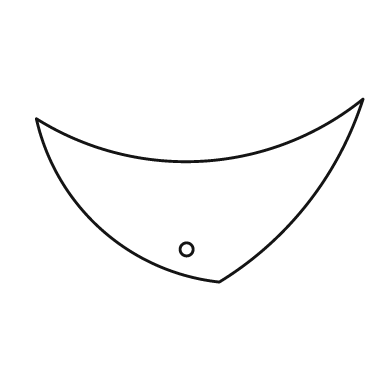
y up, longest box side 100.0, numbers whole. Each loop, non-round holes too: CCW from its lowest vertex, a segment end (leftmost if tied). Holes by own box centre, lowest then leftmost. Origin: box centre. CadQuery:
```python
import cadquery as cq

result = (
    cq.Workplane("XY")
    .moveTo(6.0, -28.0)
    .threePointArc((33.0, -4.0), (50.0, 28.0))
    .threePointArc((1.0, 9.0), (-50.0, 22.0))
    .threePointArc((-30.0, -12.0), (6.0, -28.0))
    .close()
    .moveTo(-4.0, -18.0)
    .circle(2.0)
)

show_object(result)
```